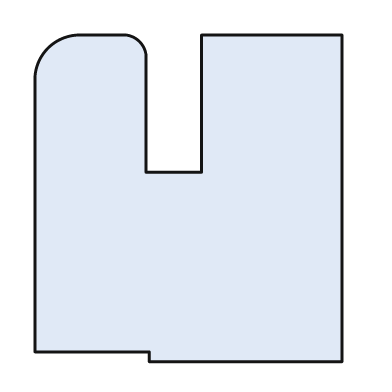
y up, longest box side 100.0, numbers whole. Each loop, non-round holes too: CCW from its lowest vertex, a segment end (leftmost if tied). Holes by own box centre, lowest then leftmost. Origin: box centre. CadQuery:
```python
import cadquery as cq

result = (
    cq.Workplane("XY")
    .moveTo(-12.0, -50.0)
    .lineTo(47.0, -50.0)
    .lineTo(47.0, 50.0)
    .lineTo(4.0, 50.0)
    .lineTo(4.0, 8.0)
    .lineTo(-13.0, 8.0)
    .lineTo(-13.0, 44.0)
    .threePointArc((-15.0, 48.0), (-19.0, 50.0))
    .lineTo(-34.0, 50.0)
    .threePointArc((-43.0, 46.0), (-47.0, 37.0))
    .lineTo(-47.0, -47.0)
    .lineTo(-12.0, -47.0)
    .close()
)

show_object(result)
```